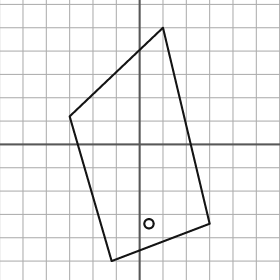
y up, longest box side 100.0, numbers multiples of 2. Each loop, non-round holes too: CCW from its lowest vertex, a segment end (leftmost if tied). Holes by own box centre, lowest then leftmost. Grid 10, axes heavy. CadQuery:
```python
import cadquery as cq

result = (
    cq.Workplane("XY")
    .moveTo(-12.0, -50.0)
    .lineTo(30.0, -34.0)
    .lineTo(10.0, 50.0)
    .lineTo(-30.0, 12.0)
    .close()
    .moveTo(4.0, -34.0)
    .circle(2.0)
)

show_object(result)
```